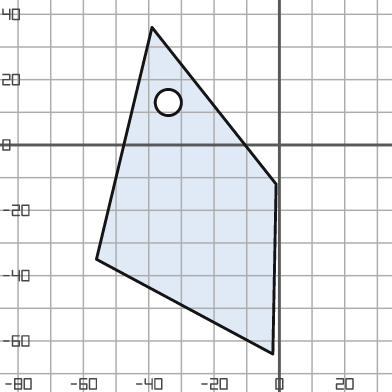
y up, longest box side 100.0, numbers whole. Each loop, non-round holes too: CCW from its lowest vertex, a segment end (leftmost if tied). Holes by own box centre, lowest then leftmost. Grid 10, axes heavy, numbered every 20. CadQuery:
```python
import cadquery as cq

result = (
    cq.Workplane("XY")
    .moveTo(-2.0, -64.0)
    .lineTo(-1.0, -12.0)
    .lineTo(-39.0, 36.0)
    .lineTo(-56.0, -35.0)
    .close()
    .moveTo(-34.0, 13.0)
    .circle(4.0)
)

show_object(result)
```